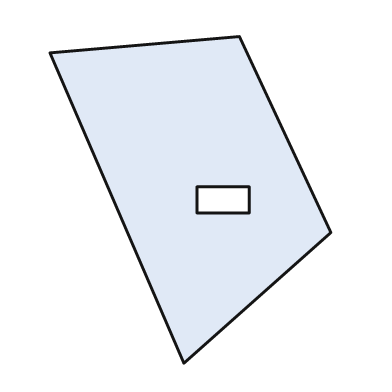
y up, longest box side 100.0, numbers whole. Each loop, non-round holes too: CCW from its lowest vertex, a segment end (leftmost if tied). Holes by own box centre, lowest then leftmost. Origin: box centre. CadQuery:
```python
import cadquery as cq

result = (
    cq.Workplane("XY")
    .moveTo(-2.0, -50.0)
    .lineTo(43.0, -10.0)
    .lineTo(15.0, 50.0)
    .lineTo(-43.0, 45.0)
    .close()
    .moveTo(2.0, -4.0)
    .lineTo(18.0, -4.0)
    .lineTo(18.0, 4.0)
    .lineTo(2.0, 4.0)
    .close()
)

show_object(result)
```